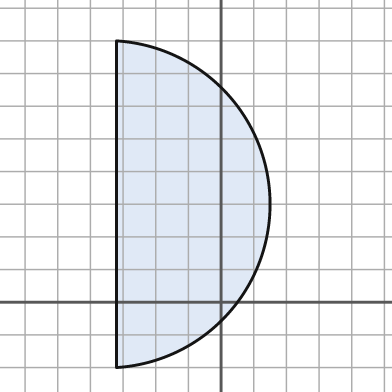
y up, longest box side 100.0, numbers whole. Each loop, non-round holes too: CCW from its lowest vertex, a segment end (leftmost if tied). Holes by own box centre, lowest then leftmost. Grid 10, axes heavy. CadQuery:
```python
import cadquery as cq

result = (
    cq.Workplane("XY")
    .moveTo(-32.0, -20.0)
    .threePointArc((15.0, 30.0), (-32.0, 80.0))
    .close()
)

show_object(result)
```